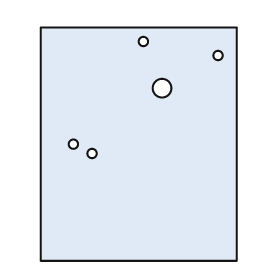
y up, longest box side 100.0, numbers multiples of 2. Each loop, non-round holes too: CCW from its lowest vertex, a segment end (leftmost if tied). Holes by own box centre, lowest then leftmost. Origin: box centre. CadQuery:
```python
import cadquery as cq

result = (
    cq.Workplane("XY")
    .moveTo(-42.0, -50.0)
    .lineTo(42.0, -50.0)
    .lineTo(42.0, 50.0)
    .lineTo(-42.0, 50.0)
    .close()
    .moveTo(-20.0, -4.0)
    .circle(2.0)
    .moveTo(-28.0, 0.0)
    .circle(2.0)
    .moveTo(10.0, 24.0)
    .circle(4.0)
    .moveTo(34.0, 38.0)
    .circle(2.0)
    .moveTo(2.0, 44.0)
    .circle(2.0)
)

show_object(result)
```